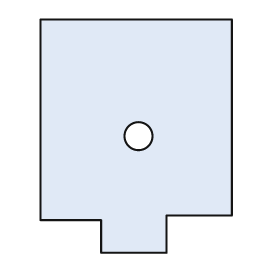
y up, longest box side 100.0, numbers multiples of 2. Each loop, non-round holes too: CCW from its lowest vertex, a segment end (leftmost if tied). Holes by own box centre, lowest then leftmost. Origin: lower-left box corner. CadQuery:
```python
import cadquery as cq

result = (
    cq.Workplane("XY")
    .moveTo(26.0, 0.0)
    .lineTo(54.0, 0.0)
    .lineTo(54.0, 16.0)
    .lineTo(82.0, 16.0)
    .lineTo(82.0, 100.0)
    .lineTo(0.0, 100.0)
    .lineTo(0.0, 14.0)
    .lineTo(26.0, 14.0)
    .close()
    .moveTo(42.0, 50.0)
    .circle(6.0)
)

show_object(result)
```